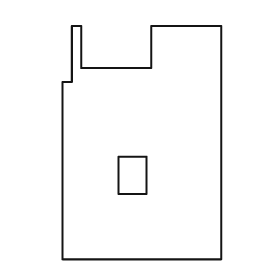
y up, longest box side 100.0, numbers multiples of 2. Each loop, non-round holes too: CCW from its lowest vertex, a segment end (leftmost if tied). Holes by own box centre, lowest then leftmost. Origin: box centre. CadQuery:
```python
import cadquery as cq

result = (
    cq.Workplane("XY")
    .moveTo(-34.0, -50.0)
    .lineTo(34.0, -50.0)
    .lineTo(34.0, 50.0)
    .lineTo(4.0, 50.0)
    .lineTo(4.0, 32.0)
    .lineTo(-26.0, 32.0)
    .lineTo(-26.0, 50.0)
    .lineTo(-30.0, 50.0)
    .lineTo(-30.0, 26.0)
    .lineTo(-34.0, 26.0)
    .close()
    .moveTo(-10.0, -22.0)
    .lineTo(2.0, -22.0)
    .lineTo(2.0, -6.0)
    .lineTo(-10.0, -6.0)
    .close()
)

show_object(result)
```